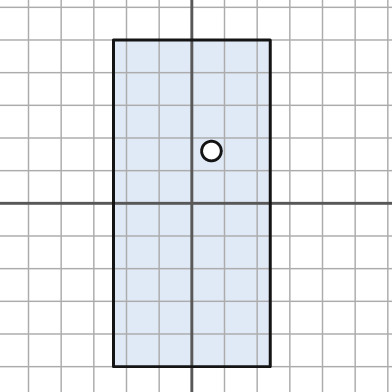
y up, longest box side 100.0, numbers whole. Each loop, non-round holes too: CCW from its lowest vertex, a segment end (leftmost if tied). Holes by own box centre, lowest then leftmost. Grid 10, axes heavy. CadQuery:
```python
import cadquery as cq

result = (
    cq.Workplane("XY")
    .moveTo(-24.0, -50.0)
    .lineTo(24.0, -50.0)
    .lineTo(24.0, 50.0)
    .lineTo(-24.0, 50.0)
    .close()
    .moveTo(6.0, 16.0)
    .circle(3.0)
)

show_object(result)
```